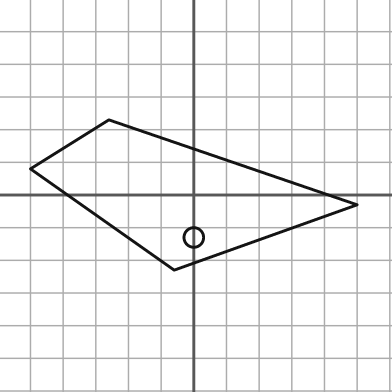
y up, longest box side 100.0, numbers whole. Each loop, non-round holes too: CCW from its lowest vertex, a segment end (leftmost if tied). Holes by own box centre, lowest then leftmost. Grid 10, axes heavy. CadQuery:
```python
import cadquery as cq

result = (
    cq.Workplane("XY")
    .moveTo(-6.0, -23.0)
    .lineTo(50.0, -3.0)
    .lineTo(-26.0, 23.0)
    .lineTo(-50.0, 8.0)
    .close()
    .moveTo(0.0, -13.0)
    .circle(3.0)
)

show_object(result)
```